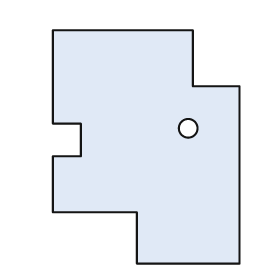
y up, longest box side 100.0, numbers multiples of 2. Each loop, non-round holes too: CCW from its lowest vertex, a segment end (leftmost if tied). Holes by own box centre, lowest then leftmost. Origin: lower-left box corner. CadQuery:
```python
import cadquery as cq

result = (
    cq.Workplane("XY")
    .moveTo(36.0, 0.0)
    .lineTo(80.0, 0.0)
    .lineTo(80.0, 76.0)
    .lineTo(60.0, 76.0)
    .lineTo(60.0, 100.0)
    .lineTo(0.0, 100.0)
    .lineTo(0.0, 60.0)
    .lineTo(12.0, 60.0)
    .lineTo(12.0, 46.0)
    .lineTo(0.0, 46.0)
    .lineTo(0.0, 22.0)
    .lineTo(36.0, 22.0)
    .close()
    .moveTo(58.0, 58.0)
    .circle(4.0)
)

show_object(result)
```